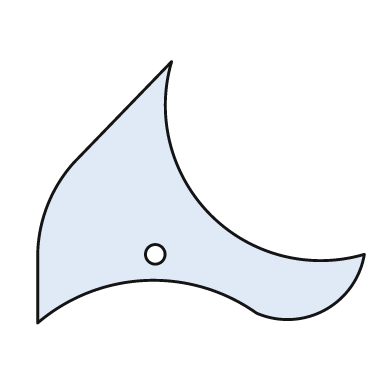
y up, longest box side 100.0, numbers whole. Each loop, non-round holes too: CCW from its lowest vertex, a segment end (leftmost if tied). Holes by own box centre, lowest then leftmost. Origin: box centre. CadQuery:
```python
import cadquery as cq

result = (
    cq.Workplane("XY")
    .moveTo(-50.0, -40.0)
    .threePointArc((-17.0, -27.0), (17.0, -37.0))
    .threePointArc((38.0, -36.0), (50.0, -19.0))
    .threePointArc((3.0, -7.0), (-9.0, 40.0))
    .lineTo(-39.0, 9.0)
    .threePointArc((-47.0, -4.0), (-50.0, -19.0))
    .close()
    .moveTo(-14.0, -19.0)
    .circle(3.0)
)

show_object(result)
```